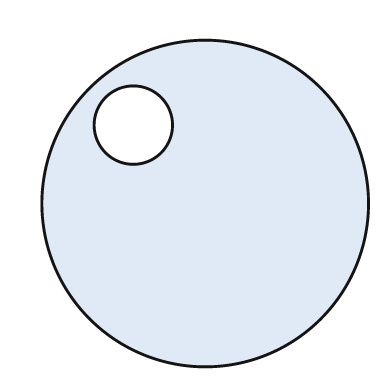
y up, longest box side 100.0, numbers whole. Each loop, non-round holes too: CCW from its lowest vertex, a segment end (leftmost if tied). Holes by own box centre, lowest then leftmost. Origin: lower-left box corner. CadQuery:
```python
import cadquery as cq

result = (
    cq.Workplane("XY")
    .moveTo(50.0, 50.0)
    .circle(50.0)
    .moveTo(28.0, 74.0)
    .circle(12.0)
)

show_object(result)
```